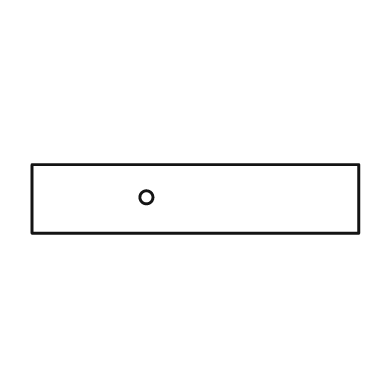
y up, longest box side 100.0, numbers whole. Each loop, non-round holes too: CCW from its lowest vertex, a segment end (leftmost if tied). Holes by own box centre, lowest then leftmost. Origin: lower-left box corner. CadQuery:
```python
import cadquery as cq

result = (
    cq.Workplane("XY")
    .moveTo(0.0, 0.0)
    .lineTo(100.0, 0.0)
    .lineTo(100.0, 21.0)
    .lineTo(0.0, 21.0)
    .close()
    .moveTo(35.0, 11.0)
    .circle(2.0)
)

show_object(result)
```